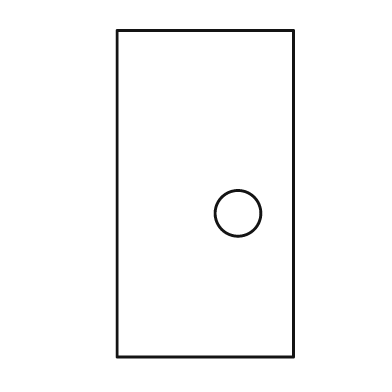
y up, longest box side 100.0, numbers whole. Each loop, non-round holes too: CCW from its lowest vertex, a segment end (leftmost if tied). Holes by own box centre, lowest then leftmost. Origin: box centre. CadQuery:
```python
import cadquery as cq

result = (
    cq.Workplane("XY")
    .moveTo(-27.0, -50.0)
    .lineTo(27.0, -50.0)
    .lineTo(27.0, 50.0)
    .lineTo(-27.0, 50.0)
    .close()
    .moveTo(10.0, -6.0)
    .circle(7.0)
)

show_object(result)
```